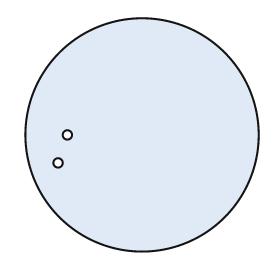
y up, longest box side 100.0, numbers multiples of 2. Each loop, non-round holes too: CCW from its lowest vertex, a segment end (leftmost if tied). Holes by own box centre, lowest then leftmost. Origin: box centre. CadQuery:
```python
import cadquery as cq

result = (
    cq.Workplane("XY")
    .moveTo(0.0, 0.0)
    .circle(50.0)
    .moveTo(-36.0, -12.0)
    .circle(2.0)
    .moveTo(-32.0, 0.0)
    .circle(2.0)
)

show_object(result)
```